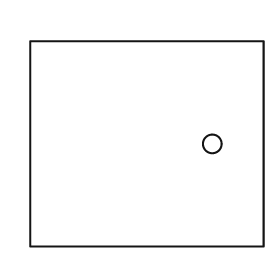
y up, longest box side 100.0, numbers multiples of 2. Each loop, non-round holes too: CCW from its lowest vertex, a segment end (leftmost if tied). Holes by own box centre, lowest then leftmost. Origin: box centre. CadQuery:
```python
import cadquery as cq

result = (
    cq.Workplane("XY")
    .moveTo(-50.0, -44.0)
    .lineTo(50.0, -44.0)
    .lineTo(50.0, 44.0)
    .lineTo(-50.0, 44.0)
    .close()
    .moveTo(28.0, 0.0)
    .circle(4.0)
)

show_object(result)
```